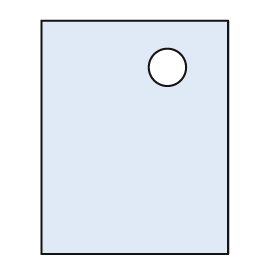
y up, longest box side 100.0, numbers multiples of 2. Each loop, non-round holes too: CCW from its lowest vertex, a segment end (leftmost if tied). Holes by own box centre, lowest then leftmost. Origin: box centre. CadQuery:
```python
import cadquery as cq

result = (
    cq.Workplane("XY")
    .moveTo(-40.0, -50.0)
    .lineTo(40.0, -50.0)
    .lineTo(40.0, 50.0)
    .lineTo(-40.0, 50.0)
    .close()
    .moveTo(14.0, 30.0)
    .circle(8.0)
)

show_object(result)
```